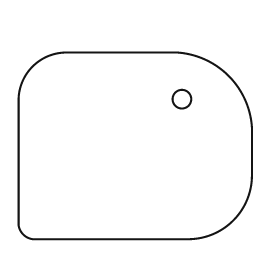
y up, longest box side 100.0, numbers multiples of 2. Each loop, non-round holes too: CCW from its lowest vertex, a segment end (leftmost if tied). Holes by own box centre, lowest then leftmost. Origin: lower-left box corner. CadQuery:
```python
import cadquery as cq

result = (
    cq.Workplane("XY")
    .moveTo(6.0, 0.0)
    .lineTo(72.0, 0.0)
    .threePointArc((92.0, 8.0), (100.0, 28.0))
    .lineTo(100.0, 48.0)
    .threePointArc((90.0, 70.0), (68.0, 80.0))
    .lineTo(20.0, 80.0)
    .threePointArc((6.0, 74.0), (0.0, 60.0))
    .lineTo(0.0, 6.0)
    .threePointArc((2.0, 2.0), (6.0, 0.0))
    .close()
    .moveTo(70.0, 60.0)
    .circle(4.0)
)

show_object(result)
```